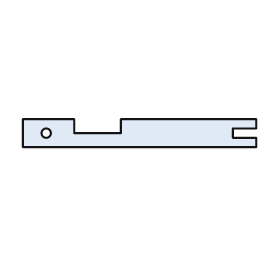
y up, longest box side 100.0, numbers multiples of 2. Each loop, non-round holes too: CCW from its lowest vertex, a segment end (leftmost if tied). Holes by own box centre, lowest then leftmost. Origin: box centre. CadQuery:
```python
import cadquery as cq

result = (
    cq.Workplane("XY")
    .moveTo(-50.0, -6.0)
    .lineTo(50.0, -6.0)
    .lineTo(50.0, -2.0)
    .lineTo(40.0, -2.0)
    .lineTo(40.0, 2.0)
    .lineTo(50.0, 2.0)
    .lineTo(50.0, 6.0)
    .lineTo(-8.0, 6.0)
    .lineTo(-8.0, 0.0)
    .lineTo(-28.0, 0.0)
    .lineTo(-28.0, 6.0)
    .lineTo(-50.0, 6.0)
    .close()
    .moveTo(-40.0, 0.0)
    .circle(2.0)
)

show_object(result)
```